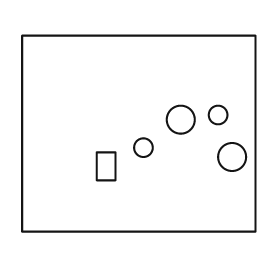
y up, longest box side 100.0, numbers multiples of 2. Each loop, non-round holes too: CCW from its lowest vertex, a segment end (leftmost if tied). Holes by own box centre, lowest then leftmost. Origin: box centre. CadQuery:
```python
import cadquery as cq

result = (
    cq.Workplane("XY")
    .moveTo(-50.0, -42.0)
    .lineTo(50.0, -42.0)
    .lineTo(50.0, 42.0)
    .lineTo(-50.0, 42.0)
    .close()
    .moveTo(-18.0, -20.0)
    .lineTo(-10.0, -20.0)
    .lineTo(-10.0, -8.0)
    .lineTo(-18.0, -8.0)
    .close()
    .moveTo(40.0, -10.0)
    .circle(6.0)
    .moveTo(2.0, -6.0)
    .circle(4.0)
    .moveTo(18.0, 6.0)
    .circle(6.0)
    .moveTo(34.0, 8.0)
    .circle(4.0)
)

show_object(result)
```